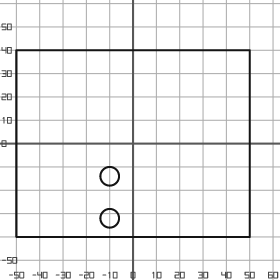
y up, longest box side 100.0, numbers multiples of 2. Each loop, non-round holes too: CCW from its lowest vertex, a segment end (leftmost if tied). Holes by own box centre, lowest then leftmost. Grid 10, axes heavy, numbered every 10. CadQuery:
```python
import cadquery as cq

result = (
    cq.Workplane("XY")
    .moveTo(-50.0, -40.0)
    .lineTo(50.0, -40.0)
    .lineTo(50.0, 40.0)
    .lineTo(-50.0, 40.0)
    .close()
    .moveTo(-10.0, -32.0)
    .circle(4.0)
    .moveTo(-10.0, -14.0)
    .circle(4.0)
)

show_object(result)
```